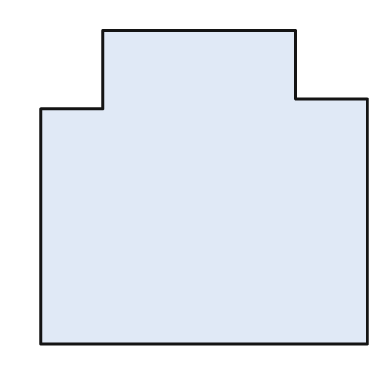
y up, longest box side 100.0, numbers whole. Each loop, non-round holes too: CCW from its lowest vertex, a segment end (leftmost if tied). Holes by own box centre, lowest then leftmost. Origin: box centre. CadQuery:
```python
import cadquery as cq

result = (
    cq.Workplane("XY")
    .moveTo(-50.0, -48.0)
    .lineTo(50.0, -48.0)
    .lineTo(50.0, 27.0)
    .lineTo(28.0, 27.0)
    .lineTo(28.0, 48.0)
    .lineTo(-31.0, 48.0)
    .lineTo(-31.0, 24.0)
    .lineTo(-50.0, 24.0)
    .close()
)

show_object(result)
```